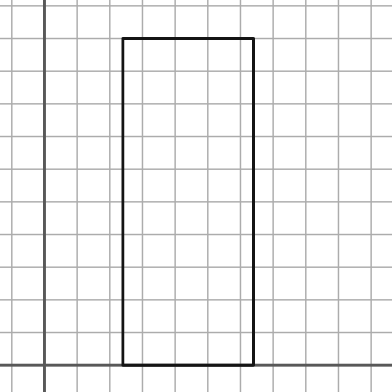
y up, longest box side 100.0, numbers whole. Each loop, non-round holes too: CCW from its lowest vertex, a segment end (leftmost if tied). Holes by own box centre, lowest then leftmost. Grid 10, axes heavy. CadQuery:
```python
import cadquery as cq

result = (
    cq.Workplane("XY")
    .moveTo(24.0, 0.0)
    .lineTo(64.0, 0.0)
    .lineTo(64.0, 100.0)
    .lineTo(24.0, 100.0)
    .close()
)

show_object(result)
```